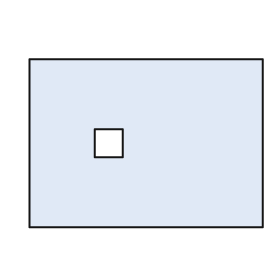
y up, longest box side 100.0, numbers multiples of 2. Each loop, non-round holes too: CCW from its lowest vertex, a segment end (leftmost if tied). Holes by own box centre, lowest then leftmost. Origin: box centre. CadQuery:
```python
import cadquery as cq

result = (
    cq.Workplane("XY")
    .moveTo(-50.0, -36.0)
    .lineTo(50.0, -36.0)
    .lineTo(50.0, 36.0)
    .lineTo(-50.0, 36.0)
    .close()
    .moveTo(-22.0, -6.0)
    .lineTo(-10.0, -6.0)
    .lineTo(-10.0, 6.0)
    .lineTo(-22.0, 6.0)
    .close()
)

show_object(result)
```